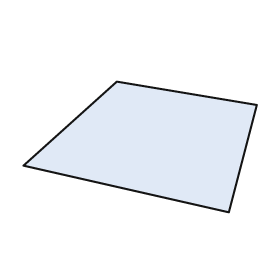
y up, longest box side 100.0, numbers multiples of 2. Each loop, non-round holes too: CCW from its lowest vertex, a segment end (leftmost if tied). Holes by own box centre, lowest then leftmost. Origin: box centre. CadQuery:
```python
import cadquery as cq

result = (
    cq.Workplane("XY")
    .moveTo(38.0, -28.0)
    .lineTo(50.0, 18.0)
    .lineTo(-10.0, 28.0)
    .lineTo(-50.0, -8.0)
    .close()
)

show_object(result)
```